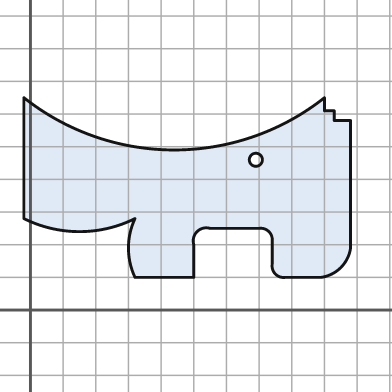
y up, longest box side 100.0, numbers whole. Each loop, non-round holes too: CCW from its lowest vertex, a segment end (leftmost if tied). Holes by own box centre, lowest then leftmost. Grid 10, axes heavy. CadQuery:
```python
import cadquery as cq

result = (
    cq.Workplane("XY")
    .moveTo(32.0, 10.0)
    .lineTo(50.0, 10.0)
    .lineTo(50.0, 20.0)
    .threePointArc((51.0, 24.0), (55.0, 25.0))
    .lineTo(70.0, 25.0)
    .threePointArc((73.0, 24.0), (74.0, 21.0))
    .lineTo(74.0, 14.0)
    .threePointArc((75.0, 11.0), (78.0, 10.0))
    .lineTo(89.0, 10.0)
    .threePointArc((95.0, 13.0), (98.0, 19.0))
    .lineTo(98.0, 58.0)
    .lineTo(93.0, 58.0)
    .lineTo(93.0, 61.0)
    .lineTo(90.0, 61.0)
    .lineTo(90.0, 65.0)
    .threePointArc((44.0, 49.0), (-2.0, 65.0))
    .lineTo(-2.0, 28.0)
    .threePointArc((15.0, 24.0), (32.0, 28.0))
    .threePointArc((30.0, 19.0), (32.0, 10.0))
    .close()
    .moveTo(69.0, 46.0)
    .circle(2.0)
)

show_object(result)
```